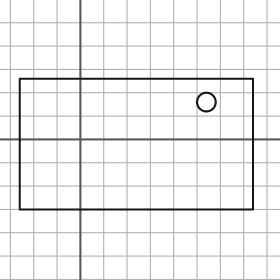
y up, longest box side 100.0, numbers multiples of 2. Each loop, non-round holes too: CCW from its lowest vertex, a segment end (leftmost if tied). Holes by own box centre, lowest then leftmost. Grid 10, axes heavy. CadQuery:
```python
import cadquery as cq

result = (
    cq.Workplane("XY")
    .moveTo(-26.0, -30.0)
    .lineTo(74.0, -30.0)
    .lineTo(74.0, 26.0)
    .lineTo(-26.0, 26.0)
    .close()
    .moveTo(54.0, 16.0)
    .circle(4.0)
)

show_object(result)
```